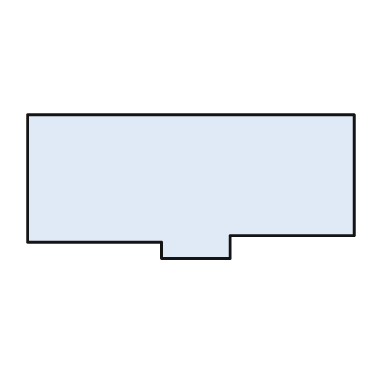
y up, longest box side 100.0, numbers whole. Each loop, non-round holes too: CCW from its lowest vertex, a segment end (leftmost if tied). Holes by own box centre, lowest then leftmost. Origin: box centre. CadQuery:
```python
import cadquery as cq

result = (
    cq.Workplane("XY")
    .moveTo(-9.0, -22.0)
    .lineTo(12.0, -22.0)
    .lineTo(12.0, -15.0)
    .lineTo(50.0, -15.0)
    .lineTo(50.0, 22.0)
    .lineTo(-50.0, 22.0)
    .lineTo(-50.0, -17.0)
    .lineTo(-9.0, -17.0)
    .close()
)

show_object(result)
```